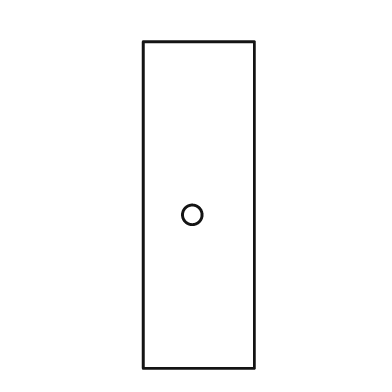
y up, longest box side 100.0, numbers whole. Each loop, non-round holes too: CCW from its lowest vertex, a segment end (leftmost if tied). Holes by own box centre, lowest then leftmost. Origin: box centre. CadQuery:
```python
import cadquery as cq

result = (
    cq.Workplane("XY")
    .moveTo(-17.0, -50.0)
    .lineTo(17.0, -50.0)
    .lineTo(17.0, 50.0)
    .lineTo(-17.0, 50.0)
    .close()
    .moveTo(-2.0, -3.0)
    .circle(3.0)
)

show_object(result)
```